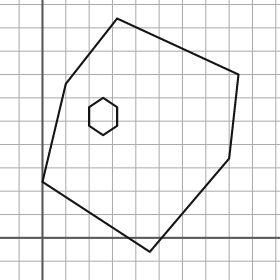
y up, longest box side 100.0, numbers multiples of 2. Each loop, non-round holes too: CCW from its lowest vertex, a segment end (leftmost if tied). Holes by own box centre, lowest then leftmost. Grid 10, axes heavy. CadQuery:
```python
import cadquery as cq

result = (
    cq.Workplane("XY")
    .moveTo(46.0, -6.0)
    .lineTo(80.0, 34.0)
    .lineTo(84.0, 70.0)
    .lineTo(32.0, 94.0)
    .lineTo(10.0, 66.0)
    .lineTo(0.0, 24.0)
    .close()
    .moveTo(26.0, 44.0)
    .lineTo(32.0, 48.0)
    .lineTo(32.0, 56.0)
    .lineTo(26.0, 60.0)
    .lineTo(20.0, 56.0)
    .lineTo(20.0, 48.0)
    .close()
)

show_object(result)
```